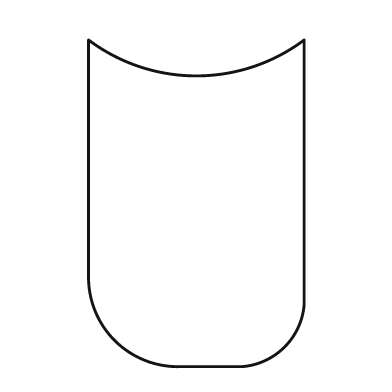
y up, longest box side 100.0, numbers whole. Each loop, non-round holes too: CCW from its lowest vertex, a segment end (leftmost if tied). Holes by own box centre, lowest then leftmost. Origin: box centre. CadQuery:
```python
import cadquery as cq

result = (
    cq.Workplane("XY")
    .moveTo(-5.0, -50.0)
    .lineTo(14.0, -50.0)
    .threePointArc((27.0, -44.0), (33.0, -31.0))
    .lineTo(33.0, 50.0)
    .threePointArc((0.0, 39.0), (-33.0, 50.0))
    .lineTo(-33.0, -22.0)
    .threePointArc((-25.0, -42.0), (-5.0, -50.0))
    .close()
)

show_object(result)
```